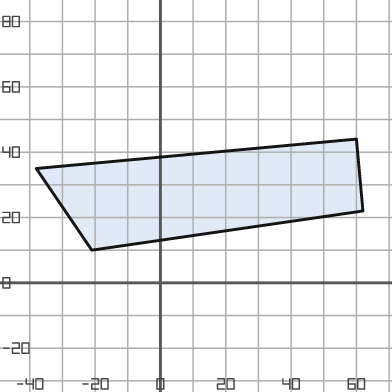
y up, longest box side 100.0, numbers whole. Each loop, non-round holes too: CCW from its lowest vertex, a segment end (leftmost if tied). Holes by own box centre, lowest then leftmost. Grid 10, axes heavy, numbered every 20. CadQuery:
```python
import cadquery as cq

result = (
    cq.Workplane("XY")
    .moveTo(-21.0, 10.0)
    .lineTo(62.0, 22.0)
    .lineTo(60.0, 44.0)
    .lineTo(-38.0, 35.0)
    .close()
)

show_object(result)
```